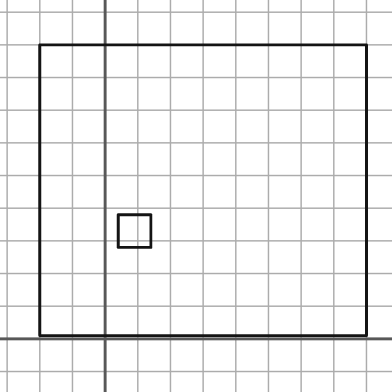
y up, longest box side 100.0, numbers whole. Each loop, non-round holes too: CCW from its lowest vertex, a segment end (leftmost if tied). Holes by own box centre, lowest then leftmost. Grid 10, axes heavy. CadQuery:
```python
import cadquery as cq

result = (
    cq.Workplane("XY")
    .moveTo(-20.0, 1.0)
    .lineTo(80.0, 1.0)
    .lineTo(80.0, 90.0)
    .lineTo(-20.0, 90.0)
    .close()
    .moveTo(4.0, 28.0)
    .lineTo(14.0, 28.0)
    .lineTo(14.0, 38.0)
    .lineTo(4.0, 38.0)
    .close()
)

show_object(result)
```